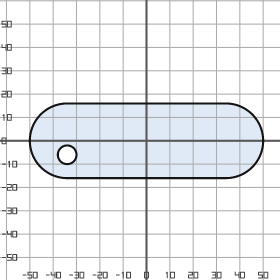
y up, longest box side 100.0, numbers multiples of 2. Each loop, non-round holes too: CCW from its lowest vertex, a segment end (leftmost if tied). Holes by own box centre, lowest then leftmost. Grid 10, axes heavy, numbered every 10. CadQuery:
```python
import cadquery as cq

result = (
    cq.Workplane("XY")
    .moveTo(-34.0, -16.0)
    .lineTo(34.0, -16.0)
    .threePointArc((50.0, 0.0), (34.0, 16.0))
    .lineTo(-34.0, 16.0)
    .threePointArc((-50.0, 0.0), (-34.0, -16.0))
    .close()
    .moveTo(-34.0, -6.0)
    .circle(4.0)
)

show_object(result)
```